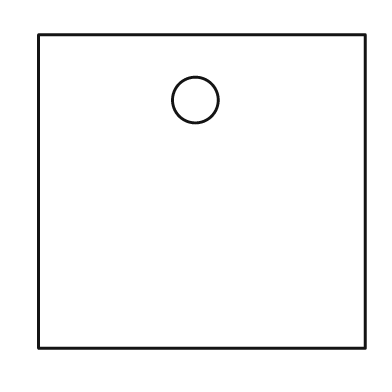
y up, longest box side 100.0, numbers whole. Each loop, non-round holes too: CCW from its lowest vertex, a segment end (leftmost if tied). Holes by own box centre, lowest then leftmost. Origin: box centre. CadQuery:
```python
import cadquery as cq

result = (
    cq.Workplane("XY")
    .moveTo(-50.0, -48.0)
    .lineTo(50.0, -48.0)
    .lineTo(50.0, 48.0)
    .lineTo(-50.0, 48.0)
    .close()
    .moveTo(-2.0, 28.0)
    .circle(7.0)
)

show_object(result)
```